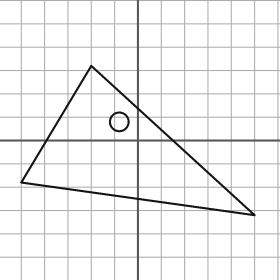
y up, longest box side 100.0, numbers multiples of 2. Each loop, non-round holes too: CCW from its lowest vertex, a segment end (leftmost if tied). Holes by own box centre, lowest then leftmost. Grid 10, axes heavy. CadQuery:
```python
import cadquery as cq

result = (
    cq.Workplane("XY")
    .moveTo(50.0, -32.0)
    .lineTo(-20.0, 32.0)
    .lineTo(-50.0, -18.0)
    .close()
    .moveTo(-8.0, 8.0)
    .circle(4.0)
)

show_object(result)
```